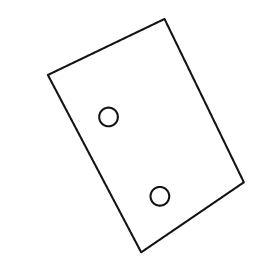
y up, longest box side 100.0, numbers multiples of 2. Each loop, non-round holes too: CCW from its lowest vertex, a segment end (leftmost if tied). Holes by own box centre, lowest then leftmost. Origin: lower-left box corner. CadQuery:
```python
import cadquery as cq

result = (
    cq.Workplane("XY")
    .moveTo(40.0, 0.0)
    .lineTo(84.0, 30.0)
    .lineTo(50.0, 100.0)
    .lineTo(0.0, 76.0)
    .close()
    .moveTo(48.0, 24.0)
    .circle(4.0)
    .moveTo(26.0, 58.0)
    .circle(4.0)
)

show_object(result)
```